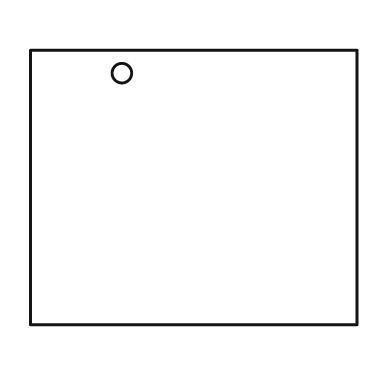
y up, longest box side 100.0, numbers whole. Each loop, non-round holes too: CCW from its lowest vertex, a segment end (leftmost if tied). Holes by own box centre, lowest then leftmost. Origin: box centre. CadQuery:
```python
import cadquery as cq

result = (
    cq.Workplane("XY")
    .moveTo(-50.0, -42.0)
    .lineTo(50.0, -42.0)
    .lineTo(50.0, 42.0)
    .lineTo(-50.0, 42.0)
    .close()
    .moveTo(-22.0, 35.0)
    .circle(3.0)
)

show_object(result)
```